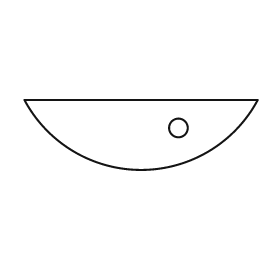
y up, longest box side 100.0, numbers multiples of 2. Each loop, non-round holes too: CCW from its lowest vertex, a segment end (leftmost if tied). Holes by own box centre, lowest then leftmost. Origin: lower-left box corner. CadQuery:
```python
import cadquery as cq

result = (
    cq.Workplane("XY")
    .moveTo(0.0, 30.0)
    .threePointArc((50.0, 0.0), (100.0, 30.0))
    .close()
    .moveTo(66.0, 18.0)
    .circle(4.0)
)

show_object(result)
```